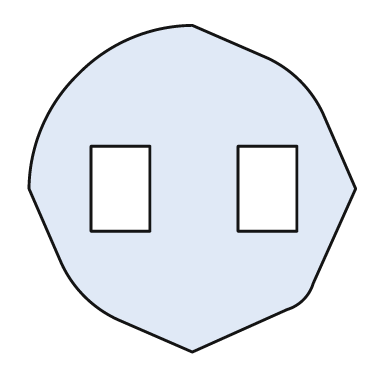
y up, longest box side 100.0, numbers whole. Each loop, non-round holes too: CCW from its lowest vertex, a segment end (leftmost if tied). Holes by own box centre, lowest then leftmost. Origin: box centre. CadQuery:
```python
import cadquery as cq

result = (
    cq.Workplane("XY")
    .moveTo(0.0, -50.0)
    .lineTo(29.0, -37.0)
    .threePointArc((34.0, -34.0), (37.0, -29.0))
    .lineTo(50.0, 0.0)
    .lineTo(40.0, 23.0)
    .threePointArc((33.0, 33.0), (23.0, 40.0))
    .lineTo(0.0, 50.0)
    .threePointArc((-19.0, 46.0), (-35.0, 35.0))
    .threePointArc((-46.0, 19.0), (-50.0, 0.0))
    .lineTo(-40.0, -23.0)
    .threePointArc((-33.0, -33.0), (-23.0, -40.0))
    .close()
    .moveTo(-31.0, -13.0)
    .lineTo(-13.0, -13.0)
    .lineTo(-13.0, 13.0)
    .lineTo(-31.0, 13.0)
    .close()
    .moveTo(14.0, -13.0)
    .lineTo(32.0, -13.0)
    .lineTo(32.0, 13.0)
    .lineTo(14.0, 13.0)
    .close()
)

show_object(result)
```